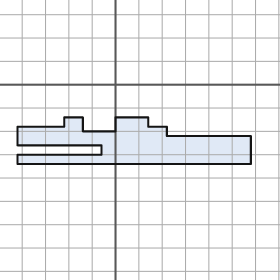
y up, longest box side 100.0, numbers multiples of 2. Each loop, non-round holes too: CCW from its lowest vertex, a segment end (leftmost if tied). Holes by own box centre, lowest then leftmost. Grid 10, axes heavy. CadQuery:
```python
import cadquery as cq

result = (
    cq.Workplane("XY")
    .moveTo(-42.0, -34.0)
    .lineTo(58.0, -34.0)
    .lineTo(58.0, -22.0)
    .lineTo(22.0, -22.0)
    .lineTo(22.0, -18.0)
    .lineTo(14.0, -18.0)
    .lineTo(14.0, -14.0)
    .lineTo(0.0, -14.0)
    .lineTo(0.0, -20.0)
    .lineTo(-14.0, -20.0)
    .lineTo(-14.0, -14.0)
    .lineTo(-22.0, -14.0)
    .lineTo(-22.0, -18.0)
    .lineTo(-42.0, -18.0)
    .lineTo(-42.0, -26.0)
    .lineTo(-6.0, -26.0)
    .lineTo(-6.0, -30.0)
    .lineTo(-42.0, -30.0)
    .close()
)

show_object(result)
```